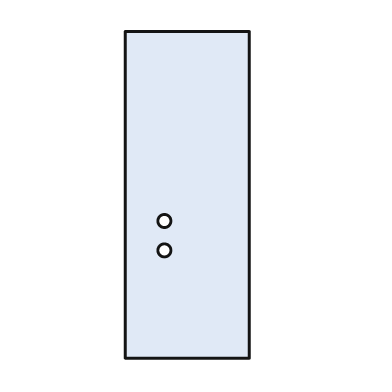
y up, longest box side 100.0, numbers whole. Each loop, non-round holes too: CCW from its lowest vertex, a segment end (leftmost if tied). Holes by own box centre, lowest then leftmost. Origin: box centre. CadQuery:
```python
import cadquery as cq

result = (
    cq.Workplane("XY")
    .moveTo(-19.0, -50.0)
    .lineTo(19.0, -50.0)
    .lineTo(19.0, 50.0)
    .lineTo(-19.0, 50.0)
    .close()
    .moveTo(-7.0, -17.0)
    .circle(2.0)
    .moveTo(-7.0, -8.0)
    .circle(2.0)
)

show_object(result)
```